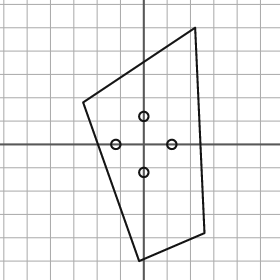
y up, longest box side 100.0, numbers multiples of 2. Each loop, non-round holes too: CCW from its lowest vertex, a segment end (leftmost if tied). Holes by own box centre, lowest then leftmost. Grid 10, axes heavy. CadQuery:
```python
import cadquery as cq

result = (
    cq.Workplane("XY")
    .moveTo(-2.0, -50.0)
    .lineTo(26.0, -38.0)
    .lineTo(22.0, 50.0)
    .lineTo(-26.0, 18.0)
    .close()
    .moveTo(0.0, -12.0)
    .circle(2.0)
    .moveTo(-12.0, 0.0)
    .circle(2.0)
    .moveTo(12.0, 0.0)
    .circle(2.0)
    .moveTo(0.0, 12.0)
    .circle(2.0)
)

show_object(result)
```